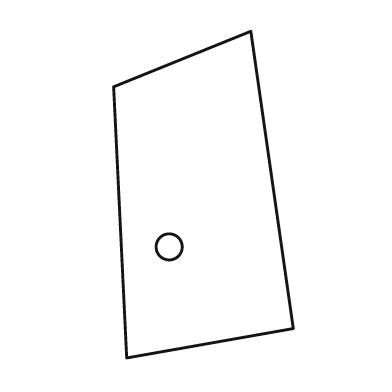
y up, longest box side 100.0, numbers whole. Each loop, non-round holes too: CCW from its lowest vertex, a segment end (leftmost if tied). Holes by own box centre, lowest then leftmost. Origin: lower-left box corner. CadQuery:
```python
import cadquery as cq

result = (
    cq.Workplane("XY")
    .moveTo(4.0, 0.0)
    .lineTo(55.0, 9.0)
    .lineTo(42.0, 100.0)
    .lineTo(0.0, 83.0)
    .close()
    .moveTo(17.0, 34.0)
    .circle(4.0)
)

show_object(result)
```